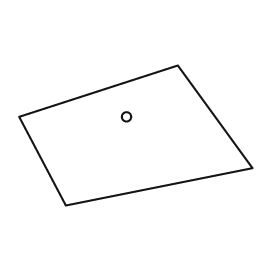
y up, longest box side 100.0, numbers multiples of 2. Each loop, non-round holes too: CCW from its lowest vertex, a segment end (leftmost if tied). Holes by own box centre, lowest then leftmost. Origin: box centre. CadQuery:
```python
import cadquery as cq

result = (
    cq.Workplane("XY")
    .moveTo(-30.0, -30.0)
    .lineTo(50.0, -14.0)
    .lineTo(18.0, 30.0)
    .lineTo(-50.0, 8.0)
    .close()
    .moveTo(-4.0, 8.0)
    .circle(2.0)
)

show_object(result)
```